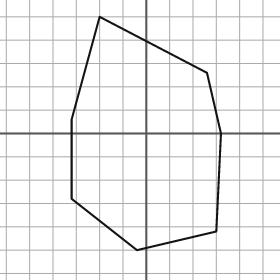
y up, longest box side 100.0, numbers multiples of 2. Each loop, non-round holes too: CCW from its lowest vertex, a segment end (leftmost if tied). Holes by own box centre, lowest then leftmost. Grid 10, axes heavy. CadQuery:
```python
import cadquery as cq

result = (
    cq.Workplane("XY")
    .moveTo(-4.0, -50.0)
    .lineTo(30.0, -42.0)
    .lineTo(32.0, 0.0)
    .lineTo(26.0, 26.0)
    .lineTo(-20.0, 50.0)
    .lineTo(-32.0, 6.0)
    .lineTo(-32.0, -28.0)
    .close()
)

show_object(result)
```